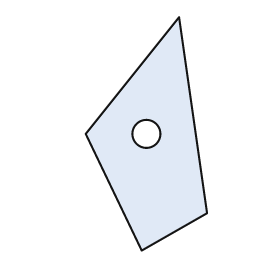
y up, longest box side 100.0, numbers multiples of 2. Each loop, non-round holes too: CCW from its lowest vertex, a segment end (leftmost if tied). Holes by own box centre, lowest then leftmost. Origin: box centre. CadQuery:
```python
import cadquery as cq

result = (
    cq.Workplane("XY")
    .moveTo(-2.0, -50.0)
    .lineTo(26.0, -34.0)
    .lineTo(14.0, 50.0)
    .lineTo(-26.0, 0.0)
    .close()
    .moveTo(0.0, 0.0)
    .circle(6.0)
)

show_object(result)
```